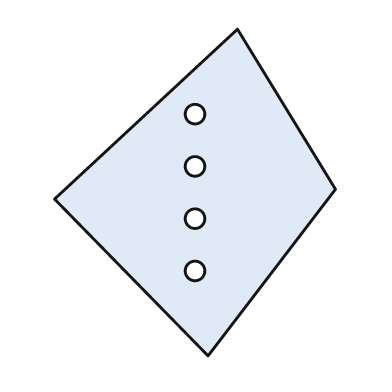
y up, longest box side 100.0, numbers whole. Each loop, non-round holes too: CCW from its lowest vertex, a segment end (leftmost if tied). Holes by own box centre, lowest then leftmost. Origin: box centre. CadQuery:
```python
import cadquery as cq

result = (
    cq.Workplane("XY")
    .moveTo(4.0, -50.0)
    .lineTo(43.0, 1.0)
    .lineTo(13.0, 50.0)
    .lineTo(-43.0, -2.0)
    .close()
    .moveTo(0.0, -24.0)
    .circle(3.0)
    .moveTo(0.0, -8.0)
    .circle(3.0)
    .moveTo(0.0, 8.0)
    .circle(3.0)
    .moveTo(0.0, 24.0)
    .circle(3.0)
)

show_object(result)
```